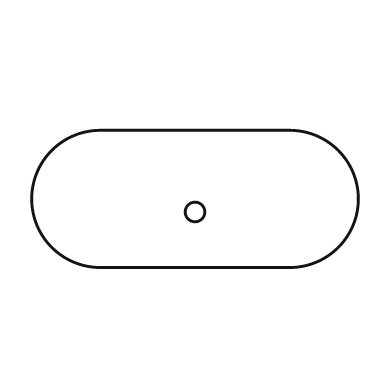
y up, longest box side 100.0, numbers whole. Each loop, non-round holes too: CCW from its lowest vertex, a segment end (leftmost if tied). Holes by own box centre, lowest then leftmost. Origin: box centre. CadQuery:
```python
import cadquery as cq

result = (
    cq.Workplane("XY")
    .moveTo(-29.0, -21.0)
    .lineTo(29.0, -21.0)
    .threePointArc((50.0, 0.0), (29.0, 21.0))
    .lineTo(-29.0, 21.0)
    .threePointArc((-50.0, 0.0), (-29.0, -21.0))
    .close()
    .moveTo(0.0, -4.0)
    .circle(3.0)
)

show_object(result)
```